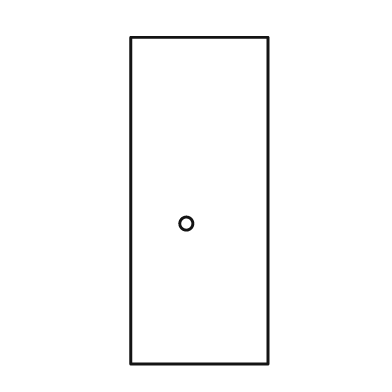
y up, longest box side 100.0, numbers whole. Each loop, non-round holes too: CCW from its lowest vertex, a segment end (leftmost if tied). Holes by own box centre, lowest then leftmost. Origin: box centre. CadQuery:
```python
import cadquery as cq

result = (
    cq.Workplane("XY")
    .moveTo(-21.0, -50.0)
    .lineTo(21.0, -50.0)
    .lineTo(21.0, 50.0)
    .lineTo(-21.0, 50.0)
    .close()
    .moveTo(-4.0, -7.0)
    .circle(2.0)
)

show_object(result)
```